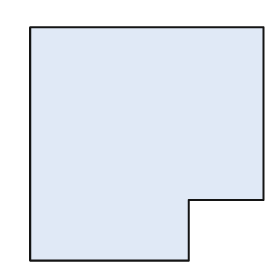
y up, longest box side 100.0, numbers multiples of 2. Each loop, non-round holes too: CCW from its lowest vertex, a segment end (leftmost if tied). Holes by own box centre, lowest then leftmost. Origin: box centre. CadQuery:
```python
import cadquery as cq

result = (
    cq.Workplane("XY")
    .moveTo(-50.0, -50.0)
    .lineTo(18.0, -50.0)
    .lineTo(18.0, -24.0)
    .lineTo(50.0, -24.0)
    .lineTo(50.0, 50.0)
    .lineTo(-50.0, 50.0)
    .close()
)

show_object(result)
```